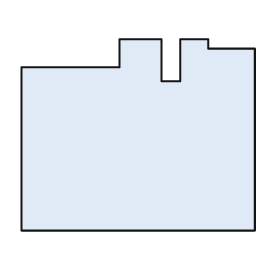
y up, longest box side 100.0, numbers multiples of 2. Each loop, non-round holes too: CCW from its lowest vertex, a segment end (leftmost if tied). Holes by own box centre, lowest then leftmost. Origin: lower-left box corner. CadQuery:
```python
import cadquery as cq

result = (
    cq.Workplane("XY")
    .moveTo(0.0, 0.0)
    .lineTo(100.0, 0.0)
    .lineTo(100.0, 78.0)
    .lineTo(80.0, 78.0)
    .lineTo(80.0, 82.0)
    .lineTo(68.0, 82.0)
    .lineTo(68.0, 64.0)
    .lineTo(60.0, 64.0)
    .lineTo(60.0, 82.0)
    .lineTo(42.0, 82.0)
    .lineTo(42.0, 70.0)
    .lineTo(0.0, 70.0)
    .close()
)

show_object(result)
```